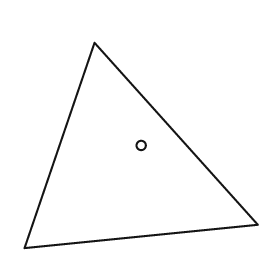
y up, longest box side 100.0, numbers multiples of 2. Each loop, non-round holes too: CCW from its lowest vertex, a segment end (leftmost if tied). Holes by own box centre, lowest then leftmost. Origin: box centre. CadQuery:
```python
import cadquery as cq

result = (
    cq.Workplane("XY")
    .moveTo(-50.0, -44.0)
    .lineTo(50.0, -34.0)
    .lineTo(-20.0, 44.0)
    .close()
    .moveTo(0.0, 0.0)
    .circle(2.0)
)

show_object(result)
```